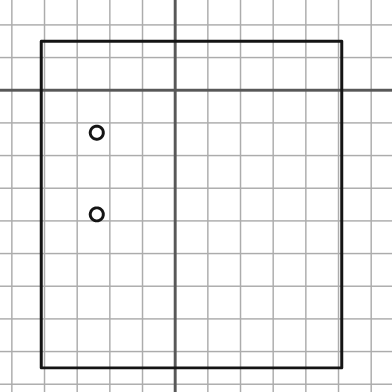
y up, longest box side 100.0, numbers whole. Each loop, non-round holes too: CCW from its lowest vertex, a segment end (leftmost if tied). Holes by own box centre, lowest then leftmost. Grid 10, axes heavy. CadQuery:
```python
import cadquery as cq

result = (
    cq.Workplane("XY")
    .moveTo(-41.0, -85.0)
    .lineTo(51.0, -85.0)
    .lineTo(51.0, 15.0)
    .lineTo(-41.0, 15.0)
    .close()
    .moveTo(-24.0, -38.0)
    .circle(2.0)
    .moveTo(-24.0, -13.0)
    .circle(2.0)
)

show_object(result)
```